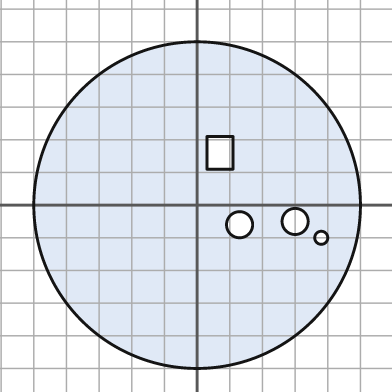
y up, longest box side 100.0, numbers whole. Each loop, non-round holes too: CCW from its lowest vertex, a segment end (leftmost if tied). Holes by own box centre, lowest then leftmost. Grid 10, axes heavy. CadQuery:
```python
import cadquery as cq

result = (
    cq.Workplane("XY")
    .moveTo(0.0, 0.0)
    .circle(50.0)
    .moveTo(38.0, -10.0)
    .circle(2.0)
    .moveTo(13.0, -6.0)
    .circle(4.0)
    .moveTo(30.0, -5.0)
    .circle(4.0)
    .moveTo(3.0, 11.0)
    .lineTo(11.0, 11.0)
    .lineTo(11.0, 21.0)
    .lineTo(3.0, 21.0)
    .close()
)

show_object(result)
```